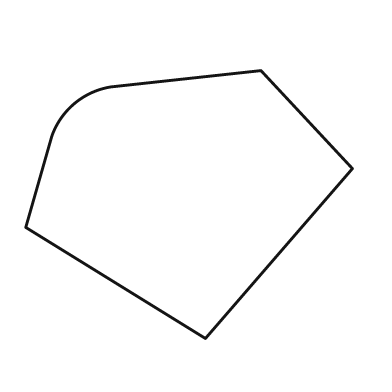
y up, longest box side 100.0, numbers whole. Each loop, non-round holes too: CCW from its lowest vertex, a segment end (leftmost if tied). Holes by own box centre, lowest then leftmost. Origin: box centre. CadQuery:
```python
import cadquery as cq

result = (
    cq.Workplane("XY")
    .moveTo(5.0, -41.0)
    .lineTo(50.0, 11.0)
    .lineTo(22.0, 41.0)
    .lineTo(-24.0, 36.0)
    .threePointArc((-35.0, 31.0), (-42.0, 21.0))
    .lineTo(-50.0, -7.0)
    .close()
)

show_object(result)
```